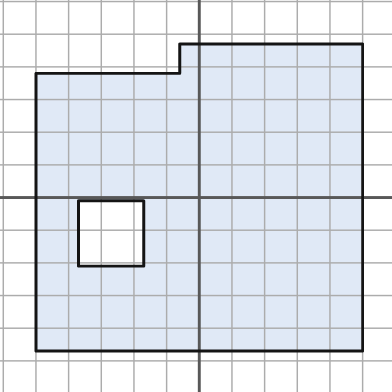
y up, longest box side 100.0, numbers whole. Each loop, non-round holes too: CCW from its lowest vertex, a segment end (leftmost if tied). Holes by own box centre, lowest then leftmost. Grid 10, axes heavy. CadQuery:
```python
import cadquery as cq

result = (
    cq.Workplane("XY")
    .moveTo(-50.0, -47.0)
    .lineTo(50.0, -47.0)
    .lineTo(50.0, 47.0)
    .lineTo(-6.0, 47.0)
    .lineTo(-6.0, 38.0)
    .lineTo(-50.0, 38.0)
    .close()
    .moveTo(-37.0, -21.0)
    .lineTo(-17.0, -21.0)
    .lineTo(-17.0, -1.0)
    .lineTo(-37.0, -1.0)
    .close()
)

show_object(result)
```